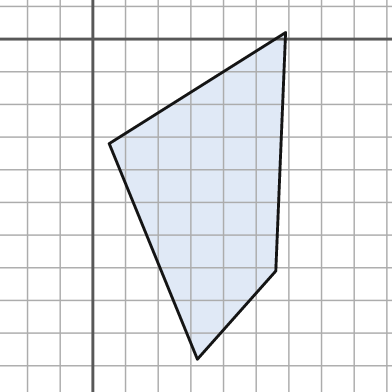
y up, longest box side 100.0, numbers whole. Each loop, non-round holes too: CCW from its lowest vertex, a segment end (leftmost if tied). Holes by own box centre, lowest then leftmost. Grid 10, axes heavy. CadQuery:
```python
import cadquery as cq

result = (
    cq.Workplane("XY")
    .moveTo(32.0, -98.0)
    .lineTo(56.0, -71.0)
    .lineTo(59.0, 2.0)
    .lineTo(5.0, -32.0)
    .close()
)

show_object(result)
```